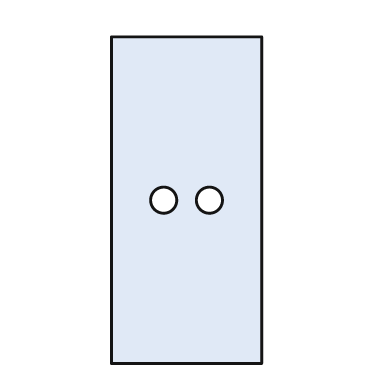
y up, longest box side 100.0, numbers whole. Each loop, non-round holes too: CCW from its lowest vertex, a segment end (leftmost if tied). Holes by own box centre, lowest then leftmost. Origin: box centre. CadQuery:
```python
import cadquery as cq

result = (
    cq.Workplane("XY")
    .moveTo(-23.0, -50.0)
    .lineTo(23.0, -50.0)
    .lineTo(23.0, 50.0)
    .lineTo(-23.0, 50.0)
    .close()
    .moveTo(-7.0, 0.0)
    .circle(4.0)
    .moveTo(7.0, 0.0)
    .circle(4.0)
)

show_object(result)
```